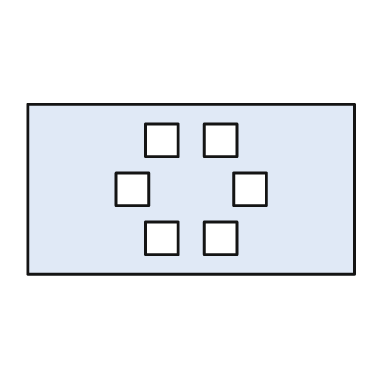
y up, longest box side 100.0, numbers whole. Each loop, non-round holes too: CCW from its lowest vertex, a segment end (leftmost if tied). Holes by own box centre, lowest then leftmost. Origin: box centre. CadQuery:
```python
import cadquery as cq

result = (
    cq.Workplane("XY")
    .moveTo(-50.0, -26.0)
    .lineTo(50.0, -26.0)
    .lineTo(50.0, 26.0)
    .lineTo(-50.0, 26.0)
    .close()
    .moveTo(-14.0, -20.0)
    .lineTo(-4.0, -20.0)
    .lineTo(-4.0, -10.0)
    .lineTo(-14.0, -10.0)
    .close()
    .moveTo(4.0, -20.0)
    .lineTo(14.0, -20.0)
    .lineTo(14.0, -10.0)
    .lineTo(4.0, -10.0)
    .close()
    .moveTo(-23.0, -5.0)
    .lineTo(-13.0, -5.0)
    .lineTo(-13.0, 5.0)
    .lineTo(-23.0, 5.0)
    .close()
    .moveTo(13.0, -5.0)
    .lineTo(23.0, -5.0)
    .lineTo(23.0, 5.0)
    .lineTo(13.0, 5.0)
    .close()
    .moveTo(-14.0, 10.0)
    .lineTo(-4.0, 10.0)
    .lineTo(-4.0, 20.0)
    .lineTo(-14.0, 20.0)
    .close()
    .moveTo(4.0, 10.0)
    .lineTo(14.0, 10.0)
    .lineTo(14.0, 20.0)
    .lineTo(4.0, 20.0)
    .close()
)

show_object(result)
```